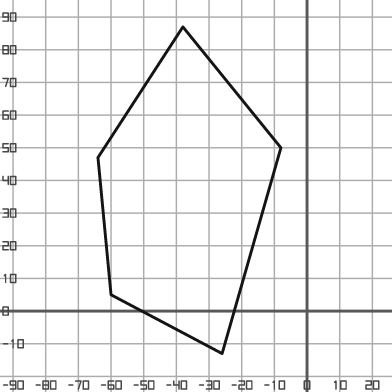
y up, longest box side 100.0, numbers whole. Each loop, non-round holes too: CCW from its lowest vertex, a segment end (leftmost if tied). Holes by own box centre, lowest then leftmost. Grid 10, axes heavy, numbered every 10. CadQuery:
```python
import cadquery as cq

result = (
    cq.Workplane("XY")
    .moveTo(-26.0, -13.0)
    .lineTo(-8.0, 50.0)
    .lineTo(-38.0, 87.0)
    .lineTo(-64.0, 47.0)
    .lineTo(-60.0, 5.0)
    .close()
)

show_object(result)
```